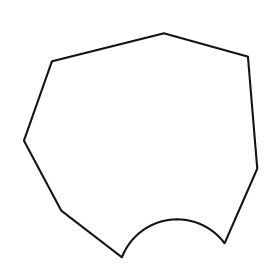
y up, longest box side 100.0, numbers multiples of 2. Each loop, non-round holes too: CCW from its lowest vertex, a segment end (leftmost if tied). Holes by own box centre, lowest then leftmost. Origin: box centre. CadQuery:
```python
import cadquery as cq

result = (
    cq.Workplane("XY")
    .moveTo(-8.0, -48.0)
    .threePointArc((12.0, -32.0), (36.0, -42.0))
    .lineTo(50.0, -10.0)
    .lineTo(46.0, 38.0)
    .lineTo(10.0, 48.0)
    .lineTo(-38.0, 36.0)
    .lineTo(-50.0, 2.0)
    .lineTo(-34.0, -28.0)
    .close()
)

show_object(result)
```